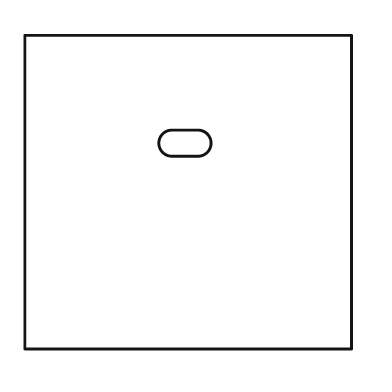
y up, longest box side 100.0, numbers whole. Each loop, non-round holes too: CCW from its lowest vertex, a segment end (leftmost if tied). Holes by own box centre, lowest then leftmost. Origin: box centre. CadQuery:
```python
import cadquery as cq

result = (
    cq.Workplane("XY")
    .moveTo(-50.0, -48.0)
    .lineTo(50.0, -48.0)
    .lineTo(50.0, 48.0)
    .lineTo(-50.0, 48.0)
    .close()
    .moveTo(-5.0, 11.0)
    .lineTo(3.0, 11.0)
    .threePointArc((7.0, 15.0), (3.0, 19.0))
    .lineTo(-5.0, 19.0)
    .threePointArc((-9.0, 15.0), (-5.0, 11.0))
    .close()
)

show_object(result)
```